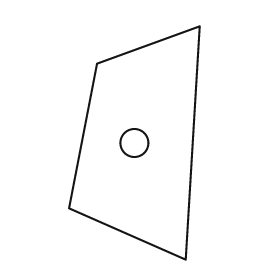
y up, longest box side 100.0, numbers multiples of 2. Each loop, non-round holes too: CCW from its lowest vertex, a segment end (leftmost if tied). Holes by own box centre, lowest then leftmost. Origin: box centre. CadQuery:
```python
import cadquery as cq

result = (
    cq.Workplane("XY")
    .moveTo(22.0, -50.0)
    .lineTo(28.0, 50.0)
    .lineTo(-16.0, 34.0)
    .lineTo(-28.0, -28.0)
    .close()
    .moveTo(0.0, 0.0)
    .circle(6.0)
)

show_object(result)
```